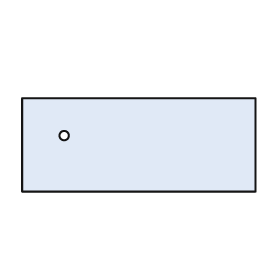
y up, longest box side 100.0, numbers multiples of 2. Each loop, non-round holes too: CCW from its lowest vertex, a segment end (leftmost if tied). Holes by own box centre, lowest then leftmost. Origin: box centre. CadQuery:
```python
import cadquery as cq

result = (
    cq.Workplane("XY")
    .moveTo(-50.0, -20.0)
    .lineTo(50.0, -20.0)
    .lineTo(50.0, 20.0)
    .lineTo(-50.0, 20.0)
    .close()
    .moveTo(-32.0, 4.0)
    .circle(2.0)
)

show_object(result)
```